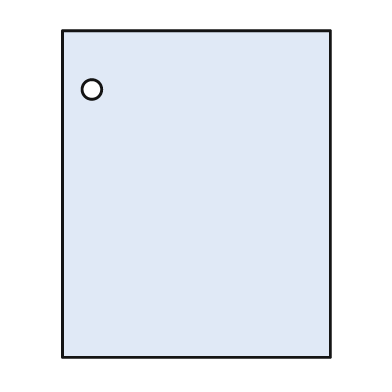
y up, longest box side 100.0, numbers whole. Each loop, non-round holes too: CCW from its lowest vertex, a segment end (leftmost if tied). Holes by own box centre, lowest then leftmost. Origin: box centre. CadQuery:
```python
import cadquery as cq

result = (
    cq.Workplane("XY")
    .moveTo(-41.0, -50.0)
    .lineTo(41.0, -50.0)
    .lineTo(41.0, 50.0)
    .lineTo(-41.0, 50.0)
    .close()
    .moveTo(-32.0, 32.0)
    .circle(3.0)
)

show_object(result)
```